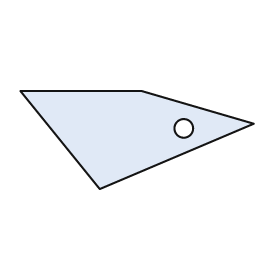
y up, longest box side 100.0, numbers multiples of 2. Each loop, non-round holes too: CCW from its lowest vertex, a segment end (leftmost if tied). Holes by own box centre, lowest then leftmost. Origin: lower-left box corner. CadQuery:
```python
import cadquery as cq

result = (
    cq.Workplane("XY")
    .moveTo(34.0, 0.0)
    .lineTo(100.0, 28.0)
    .lineTo(52.0, 42.0)
    .lineTo(0.0, 42.0)
    .close()
    .moveTo(70.0, 26.0)
    .circle(4.0)
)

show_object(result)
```